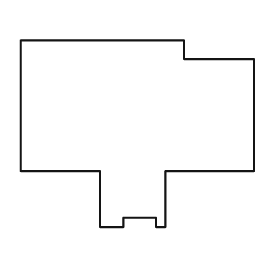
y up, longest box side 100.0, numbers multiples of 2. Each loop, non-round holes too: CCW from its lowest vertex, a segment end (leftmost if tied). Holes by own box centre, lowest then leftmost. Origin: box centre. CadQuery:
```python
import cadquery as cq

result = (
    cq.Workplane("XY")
    .moveTo(-16.0, -40.0)
    .lineTo(-6.0, -40.0)
    .lineTo(-6.0, -36.0)
    .lineTo(8.0, -36.0)
    .lineTo(8.0, -40.0)
    .lineTo(12.0, -40.0)
    .lineTo(12.0, -16.0)
    .lineTo(50.0, -16.0)
    .lineTo(50.0, 32.0)
    .lineTo(20.0, 32.0)
    .lineTo(20.0, 40.0)
    .lineTo(-50.0, 40.0)
    .lineTo(-50.0, -16.0)
    .lineTo(-16.0, -16.0)
    .close()
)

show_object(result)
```